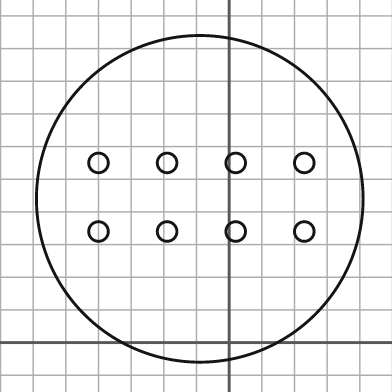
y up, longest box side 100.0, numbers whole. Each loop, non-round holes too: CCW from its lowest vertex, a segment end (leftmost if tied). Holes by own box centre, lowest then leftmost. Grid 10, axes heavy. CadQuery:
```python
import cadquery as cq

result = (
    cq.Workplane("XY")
    .moveTo(-9.0, 44.0)
    .circle(50.0)
    .moveTo(-40.0, 34.0)
    .circle(3.0)
    .moveTo(-19.0, 34.0)
    .circle(3.0)
    .moveTo(2.0, 34.0)
    .circle(3.0)
    .moveTo(23.0, 34.0)
    .circle(3.0)
    .moveTo(-40.0, 55.0)
    .circle(3.0)
    .moveTo(-19.0, 55.0)
    .circle(3.0)
    .moveTo(2.0, 55.0)
    .circle(3.0)
    .moveTo(23.0, 55.0)
    .circle(3.0)
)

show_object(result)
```